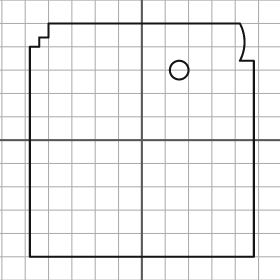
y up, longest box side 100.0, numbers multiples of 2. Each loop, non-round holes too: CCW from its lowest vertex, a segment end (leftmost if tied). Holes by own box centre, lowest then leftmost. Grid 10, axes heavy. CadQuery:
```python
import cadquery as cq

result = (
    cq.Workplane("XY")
    .moveTo(-48.0, -50.0)
    .lineTo(48.0, -50.0)
    .lineTo(48.0, 34.0)
    .lineTo(42.0, 34.0)
    .threePointArc((44.0, 42.0), (42.0, 50.0))
    .lineTo(-40.0, 50.0)
    .lineTo(-40.0, 44.0)
    .lineTo(-44.0, 44.0)
    .lineTo(-44.0, 40.0)
    .lineTo(-48.0, 40.0)
    .close()
    .moveTo(16.0, 30.0)
    .circle(4.0)
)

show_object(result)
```